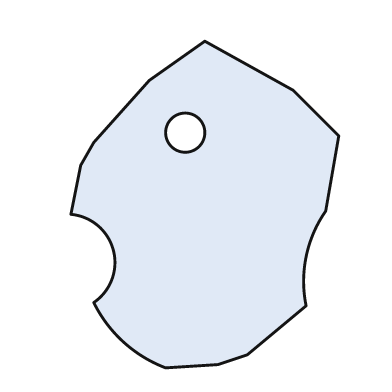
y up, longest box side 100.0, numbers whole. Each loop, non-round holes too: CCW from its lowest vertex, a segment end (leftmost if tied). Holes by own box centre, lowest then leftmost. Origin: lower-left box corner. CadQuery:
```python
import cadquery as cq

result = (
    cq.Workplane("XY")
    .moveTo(29.0, 0.0)
    .lineTo(45.0, 1.0)
    .lineTo(54.0, 4.0)
    .lineTo(72.0, 19.0)
    .threePointArc((72.0, 34.0), (78.0, 48.0))
    .lineTo(82.0, 71.0)
    .lineTo(68.0, 85.0)
    .lineTo(41.0, 100.0)
    .lineTo(24.0, 88.0)
    .lineTo(7.0, 69.0)
    .lineTo(3.0, 62.0)
    .lineTo(0.0, 47.0)
    .threePointArc((13.0, 36.0), (7.0, 20.0))
    .threePointArc((16.0, 8.0), (29.0, 0.0))
    .close()
    .moveTo(35.0, 72.0)
    .circle(6.0)
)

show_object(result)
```